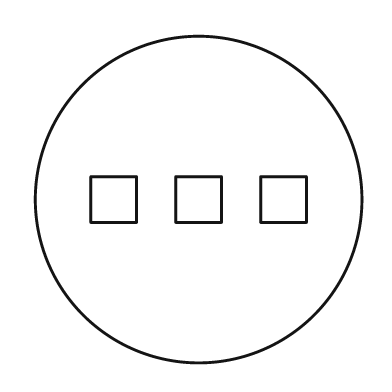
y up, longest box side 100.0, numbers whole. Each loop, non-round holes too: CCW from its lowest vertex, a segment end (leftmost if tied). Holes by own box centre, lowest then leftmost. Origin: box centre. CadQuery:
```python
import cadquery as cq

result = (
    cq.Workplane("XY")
    .moveTo(0.0, 0.0)
    .circle(50.0)
    .moveTo(-33.0, -7.0)
    .lineTo(-19.0, -7.0)
    .lineTo(-19.0, 7.0)
    .lineTo(-33.0, 7.0)
    .close()
    .moveTo(-7.0, -7.0)
    .lineTo(7.0, -7.0)
    .lineTo(7.0, 7.0)
    .lineTo(-7.0, 7.0)
    .close()
    .moveTo(19.0, -7.0)
    .lineTo(33.0, -7.0)
    .lineTo(33.0, 7.0)
    .lineTo(19.0, 7.0)
    .close()
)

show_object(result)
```